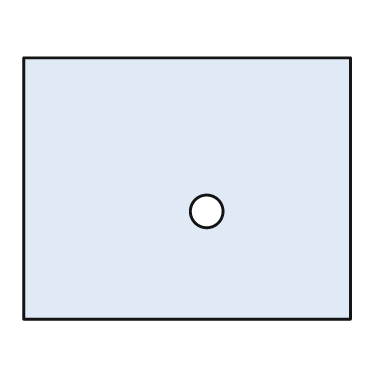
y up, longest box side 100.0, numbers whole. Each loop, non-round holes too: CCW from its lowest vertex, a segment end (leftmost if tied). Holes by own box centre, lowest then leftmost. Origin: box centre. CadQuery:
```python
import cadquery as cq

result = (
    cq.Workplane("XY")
    .moveTo(-50.0, -40.0)
    .lineTo(50.0, -40.0)
    .lineTo(50.0, 40.0)
    .lineTo(-50.0, 40.0)
    .close()
    .moveTo(6.0, -7.0)
    .circle(5.0)
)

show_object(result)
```